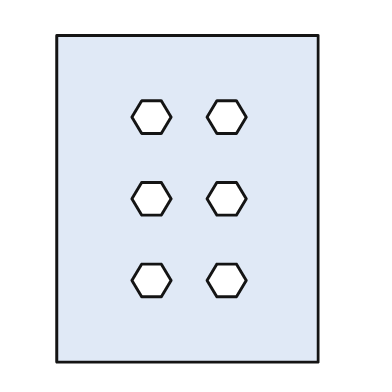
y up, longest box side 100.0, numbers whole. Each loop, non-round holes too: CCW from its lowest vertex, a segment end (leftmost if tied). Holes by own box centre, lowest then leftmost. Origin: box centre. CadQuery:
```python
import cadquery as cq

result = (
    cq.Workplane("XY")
    .moveTo(-40.0, -50.0)
    .lineTo(40.0, -50.0)
    .lineTo(40.0, 50.0)
    .lineTo(-40.0, 50.0)
    .close()
    .moveTo(-14.0, -30.0)
    .lineTo(-8.0, -30.0)
    .lineTo(-5.0, -25.0)
    .lineTo(-8.0, -20.0)
    .lineTo(-14.0, -20.0)
    .lineTo(-17.0, -25.0)
    .close()
    .moveTo(9.0, -30.0)
    .lineTo(15.0, -30.0)
    .lineTo(18.0, -25.0)
    .lineTo(15.0, -20.0)
    .lineTo(9.0, -20.0)
    .lineTo(6.0, -25.0)
    .close()
    .moveTo(-14.0, -5.0)
    .lineTo(-8.0, -5.0)
    .lineTo(-5.0, 0.0)
    .lineTo(-8.0, 5.0)
    .lineTo(-14.0, 5.0)
    .lineTo(-17.0, 0.0)
    .close()
    .moveTo(9.0, -5.0)
    .lineTo(15.0, -5.0)
    .lineTo(18.0, 0.0)
    .lineTo(15.0, 5.0)
    .lineTo(9.0, 5.0)
    .lineTo(6.0, 0.0)
    .close()
    .moveTo(-14.0, 20.0)
    .lineTo(-8.0, 20.0)
    .lineTo(-5.0, 25.0)
    .lineTo(-8.0, 30.0)
    .lineTo(-14.0, 30.0)
    .lineTo(-17.0, 25.0)
    .close()
    .moveTo(9.0, 20.0)
    .lineTo(15.0, 20.0)
    .lineTo(18.0, 25.0)
    .lineTo(15.0, 30.0)
    .lineTo(9.0, 30.0)
    .lineTo(6.0, 25.0)
    .close()
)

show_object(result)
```